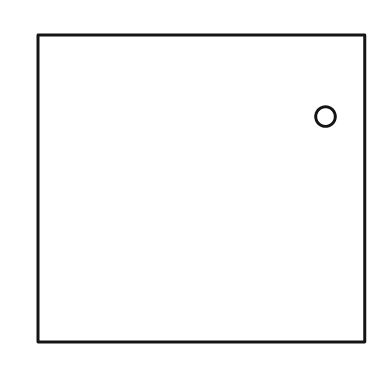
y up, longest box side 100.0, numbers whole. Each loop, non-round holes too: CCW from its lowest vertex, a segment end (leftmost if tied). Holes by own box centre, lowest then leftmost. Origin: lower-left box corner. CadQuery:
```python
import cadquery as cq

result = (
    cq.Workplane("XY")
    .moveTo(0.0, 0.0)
    .lineTo(100.0, 0.0)
    .lineTo(100.0, 94.0)
    .lineTo(0.0, 94.0)
    .close()
    .moveTo(88.0, 69.0)
    .circle(3.0)
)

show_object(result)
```